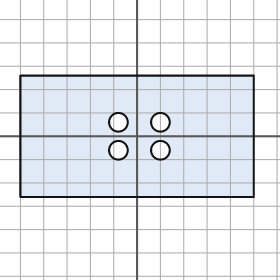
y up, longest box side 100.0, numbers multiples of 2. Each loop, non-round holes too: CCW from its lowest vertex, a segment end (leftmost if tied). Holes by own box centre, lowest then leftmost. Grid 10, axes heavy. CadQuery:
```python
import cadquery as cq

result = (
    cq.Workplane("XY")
    .moveTo(-50.0, -26.0)
    .lineTo(50.0, -26.0)
    .lineTo(50.0, 26.0)
    .lineTo(-50.0, 26.0)
    .close()
    .moveTo(-8.0, -6.0)
    .circle(4.0)
    .moveTo(10.0, -6.0)
    .circle(4.0)
    .moveTo(-8.0, 6.0)
    .circle(4.0)
    .moveTo(10.0, 6.0)
    .circle(4.0)
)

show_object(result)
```